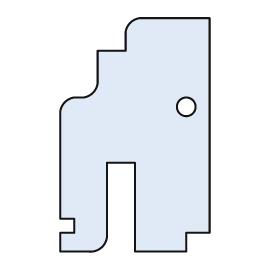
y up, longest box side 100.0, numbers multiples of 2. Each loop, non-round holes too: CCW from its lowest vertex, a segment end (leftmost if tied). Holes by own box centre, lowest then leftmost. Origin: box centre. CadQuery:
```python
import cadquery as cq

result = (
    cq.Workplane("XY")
    .moveTo(-32.0, -50.0)
    .lineTo(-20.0, -50.0)
    .threePointArc((-14.0, -48.0), (-12.0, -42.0))
    .lineTo(-12.0, -12.0)
    .lineTo(0.0, -12.0)
    .lineTo(0.0, -50.0)
    .lineTo(22.0, -50.0)
    .lineTo(22.0, -42.0)
    .lineTo(32.0, -42.0)
    .lineTo(32.0, 50.0)
    .lineTo(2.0, 50.0)
    .threePointArc((-2.0, 48.0), (-4.0, 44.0))
    .lineTo(-4.0, 36.0)
    .lineTo(-16.0, 36.0)
    .lineTo(-16.0, 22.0)
    .threePointArc((-18.0, 18.0), (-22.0, 16.0))
    .lineTo(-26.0, 16.0)
    .threePointArc((-30.0, 14.0), (-32.0, 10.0))
    .lineTo(-32.0, -36.0)
    .lineTo(-26.0, -36.0)
    .lineTo(-26.0, -42.0)
    .lineTo(-32.0, -42.0)
    .close()
    .moveTo(22.0, 12.0)
    .circle(4.0)
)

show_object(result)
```